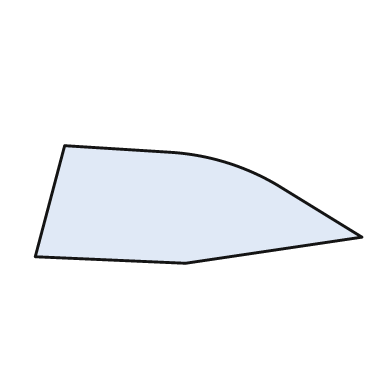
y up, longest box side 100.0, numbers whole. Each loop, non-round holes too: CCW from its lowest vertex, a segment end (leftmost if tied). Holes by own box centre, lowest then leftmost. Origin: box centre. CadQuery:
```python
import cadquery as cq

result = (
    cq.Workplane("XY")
    .moveTo(-4.0, -18.0)
    .lineTo(50.0, -10.0)
    .lineTo(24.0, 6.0)
    .threePointArc((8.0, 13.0), (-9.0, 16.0))
    .lineTo(-41.0, 18.0)
    .lineTo(-50.0, -16.0)
    .close()
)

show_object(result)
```